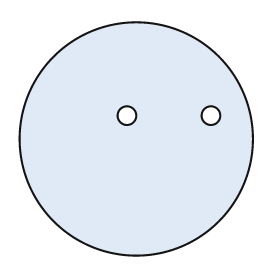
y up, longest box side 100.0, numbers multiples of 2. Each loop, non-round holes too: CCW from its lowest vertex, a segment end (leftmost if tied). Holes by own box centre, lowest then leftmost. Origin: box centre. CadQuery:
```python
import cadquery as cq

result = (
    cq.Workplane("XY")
    .moveTo(0.0, 0.0)
    .circle(50.0)
    .moveTo(-4.0, 10.0)
    .circle(4.0)
    .moveTo(32.0, 10.0)
    .circle(4.0)
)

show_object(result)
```